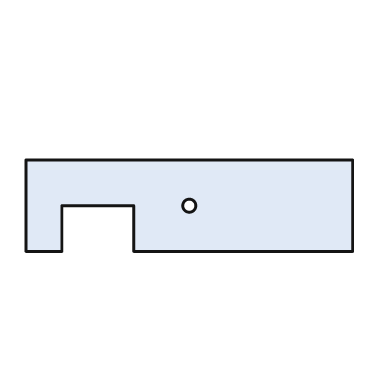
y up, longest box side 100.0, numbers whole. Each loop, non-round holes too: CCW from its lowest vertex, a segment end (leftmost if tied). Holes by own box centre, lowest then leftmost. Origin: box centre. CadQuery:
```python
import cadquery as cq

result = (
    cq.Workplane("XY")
    .moveTo(-50.0, -14.0)
    .lineTo(-39.0, -14.0)
    .lineTo(-39.0, 0.0)
    .lineTo(-17.0, 0.0)
    .lineTo(-17.0, -14.0)
    .lineTo(50.0, -14.0)
    .lineTo(50.0, 14.0)
    .lineTo(-50.0, 14.0)
    .close()
    .moveTo(0.0, 0.0)
    .circle(2.0)
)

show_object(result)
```